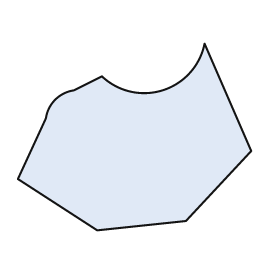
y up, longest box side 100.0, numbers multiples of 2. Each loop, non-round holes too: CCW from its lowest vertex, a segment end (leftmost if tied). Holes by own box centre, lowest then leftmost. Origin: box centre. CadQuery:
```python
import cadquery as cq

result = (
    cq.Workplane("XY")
    .moveTo(-16.0, -40.0)
    .lineTo(22.0, -36.0)
    .lineTo(50.0, -6.0)
    .lineTo(30.0, 40.0)
    .threePointArc((12.0, 20.0), (-14.0, 26.0))
    .lineTo(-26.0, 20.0)
    .threePointArc((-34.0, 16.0), (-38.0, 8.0))
    .lineTo(-50.0, -18.0)
    .close()
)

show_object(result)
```